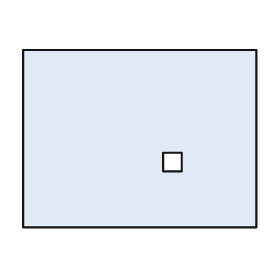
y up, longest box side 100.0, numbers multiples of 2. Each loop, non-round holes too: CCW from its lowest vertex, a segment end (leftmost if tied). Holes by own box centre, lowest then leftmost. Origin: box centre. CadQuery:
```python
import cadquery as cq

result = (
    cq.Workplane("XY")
    .moveTo(-50.0, -38.0)
    .lineTo(50.0, -38.0)
    .lineTo(50.0, 38.0)
    .lineTo(-50.0, 38.0)
    .close()
    .moveTo(10.0, -14.0)
    .lineTo(18.0, -14.0)
    .lineTo(18.0, -6.0)
    .lineTo(10.0, -6.0)
    .close()
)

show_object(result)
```